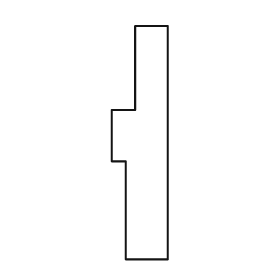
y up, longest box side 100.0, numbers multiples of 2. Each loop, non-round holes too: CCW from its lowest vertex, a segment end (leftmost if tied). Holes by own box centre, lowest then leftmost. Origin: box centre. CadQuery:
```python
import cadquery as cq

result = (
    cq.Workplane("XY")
    .moveTo(-6.0, -50.0)
    .lineTo(12.0, -50.0)
    .lineTo(12.0, 50.0)
    .lineTo(-2.0, 50.0)
    .lineTo(-2.0, 14.0)
    .lineTo(-12.0, 14.0)
    .lineTo(-12.0, -8.0)
    .lineTo(-6.0, -8.0)
    .close()
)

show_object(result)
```